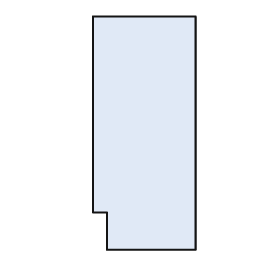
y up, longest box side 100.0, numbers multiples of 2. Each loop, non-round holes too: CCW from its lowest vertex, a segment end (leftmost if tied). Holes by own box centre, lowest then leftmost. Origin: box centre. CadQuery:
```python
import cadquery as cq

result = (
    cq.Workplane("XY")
    .moveTo(-16.0, -50.0)
    .lineTo(22.0, -50.0)
    .lineTo(22.0, 50.0)
    .lineTo(-22.0, 50.0)
    .lineTo(-22.0, -34.0)
    .lineTo(-16.0, -34.0)
    .close()
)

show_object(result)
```